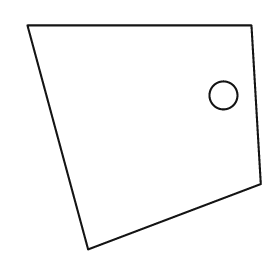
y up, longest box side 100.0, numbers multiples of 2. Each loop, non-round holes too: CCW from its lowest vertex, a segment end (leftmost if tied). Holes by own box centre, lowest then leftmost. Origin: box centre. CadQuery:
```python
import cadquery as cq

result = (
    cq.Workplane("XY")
    .moveTo(-24.0, -48.0)
    .lineTo(50.0, -20.0)
    .lineTo(46.0, 48.0)
    .lineTo(-50.0, 48.0)
    .close()
    .moveTo(34.0, 18.0)
    .circle(6.0)
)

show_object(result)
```